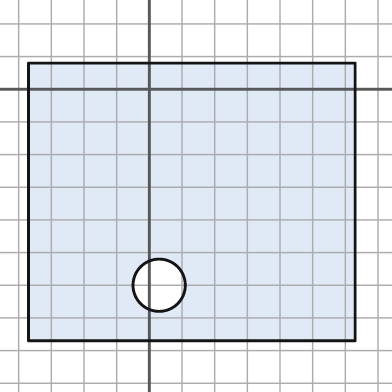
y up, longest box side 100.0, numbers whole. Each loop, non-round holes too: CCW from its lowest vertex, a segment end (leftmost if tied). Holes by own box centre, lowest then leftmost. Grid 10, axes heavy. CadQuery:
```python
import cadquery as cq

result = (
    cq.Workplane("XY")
    .moveTo(-37.0, -77.0)
    .lineTo(63.0, -77.0)
    .lineTo(63.0, 8.0)
    .lineTo(-37.0, 8.0)
    .close()
    .moveTo(3.0, -60.0)
    .circle(8.0)
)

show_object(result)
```